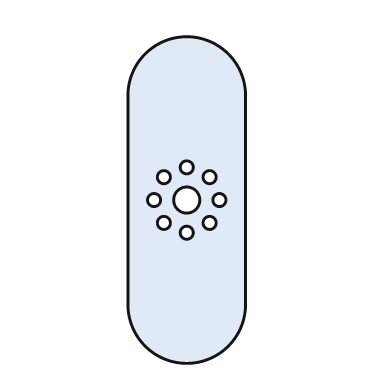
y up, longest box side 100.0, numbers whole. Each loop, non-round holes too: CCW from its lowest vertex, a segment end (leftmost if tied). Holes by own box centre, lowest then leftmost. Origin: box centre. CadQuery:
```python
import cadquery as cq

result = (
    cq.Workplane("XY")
    .moveTo(-18.0, -32.0)
    .threePointArc((0.0, -50.0), (18.0, -32.0))
    .lineTo(18.0, 32.0)
    .threePointArc((0.0, 50.0), (-18.0, 32.0))
    .close()
    .moveTo(0.0, -10.0)
    .circle(2.0)
    .moveTo(-7.0, -7.0)
    .circle(2.0)
    .moveTo(7.0, -7.0)
    .circle(2.0)
    .moveTo(-10.0, 0.0)
    .circle(2.0)
    .moveTo(0.0, 0.0)
    .circle(4.0)
    .moveTo(10.0, 0.0)
    .circle(2.0)
    .moveTo(-7.0, 7.0)
    .circle(2.0)
    .moveTo(7.0, 7.0)
    .circle(2.0)
    .moveTo(0.0, 10.0)
    .circle(2.0)
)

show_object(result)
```